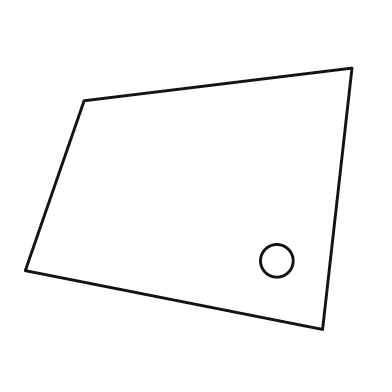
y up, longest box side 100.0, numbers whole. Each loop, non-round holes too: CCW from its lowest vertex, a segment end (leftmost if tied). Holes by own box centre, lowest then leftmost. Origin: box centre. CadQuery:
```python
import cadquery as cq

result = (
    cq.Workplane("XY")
    .moveTo(41.0, -40.0)
    .lineTo(50.0, 40.0)
    .lineTo(-32.0, 30.0)
    .lineTo(-50.0, -22.0)
    .close()
    .moveTo(27.0, -19.0)
    .circle(5.0)
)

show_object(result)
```